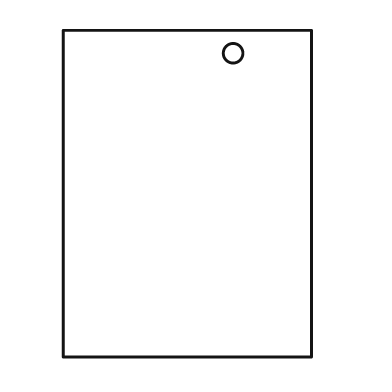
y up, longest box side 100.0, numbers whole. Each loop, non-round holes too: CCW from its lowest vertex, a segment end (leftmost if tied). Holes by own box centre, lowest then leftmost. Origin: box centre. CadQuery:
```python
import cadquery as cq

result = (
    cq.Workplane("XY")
    .moveTo(-38.0, -50.0)
    .lineTo(38.0, -50.0)
    .lineTo(38.0, 50.0)
    .lineTo(-38.0, 50.0)
    .close()
    .moveTo(14.0, 43.0)
    .circle(3.0)
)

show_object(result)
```